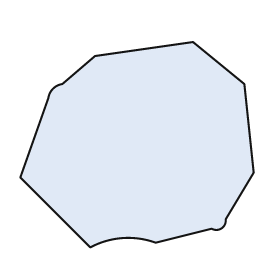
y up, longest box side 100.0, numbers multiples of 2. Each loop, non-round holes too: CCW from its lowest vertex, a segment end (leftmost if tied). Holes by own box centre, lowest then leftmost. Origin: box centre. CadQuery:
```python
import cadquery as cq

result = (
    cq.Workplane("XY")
    .moveTo(-20.0, -44.0)
    .threePointArc((-6.0, -40.0), (8.0, -42.0))
    .lineTo(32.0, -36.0)
    .threePointArc((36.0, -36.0), (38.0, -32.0))
    .lineTo(50.0, -12.0)
    .lineTo(46.0, 26.0)
    .lineTo(24.0, 44.0)
    .lineTo(-18.0, 38.0)
    .lineTo(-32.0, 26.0)
    .threePointArc((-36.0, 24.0), (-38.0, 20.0))
    .lineTo(-50.0, -14.0)
    .close()
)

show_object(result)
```